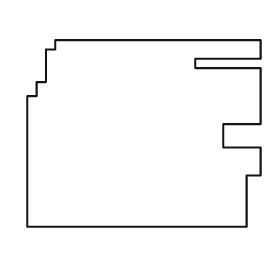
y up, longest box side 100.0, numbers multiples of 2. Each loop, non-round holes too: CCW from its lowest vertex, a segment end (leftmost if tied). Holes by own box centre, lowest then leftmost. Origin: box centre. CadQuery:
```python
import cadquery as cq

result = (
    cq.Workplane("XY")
    .moveTo(-50.0, -40.0)
    .lineTo(44.0, -40.0)
    .lineTo(44.0, -18.0)
    .lineTo(50.0, -18.0)
    .lineTo(50.0, -6.0)
    .lineTo(34.0, -6.0)
    .lineTo(34.0, 4.0)
    .lineTo(50.0, 4.0)
    .lineTo(50.0, 28.0)
    .lineTo(22.0, 28.0)
    .lineTo(22.0, 32.0)
    .lineTo(50.0, 32.0)
    .lineTo(50.0, 40.0)
    .lineTo(-38.0, 40.0)
    .lineTo(-38.0, 36.0)
    .lineTo(-42.0, 36.0)
    .lineTo(-42.0, 22.0)
    .lineTo(-46.0, 22.0)
    .lineTo(-46.0, 16.0)
    .lineTo(-50.0, 16.0)
    .close()
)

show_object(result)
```